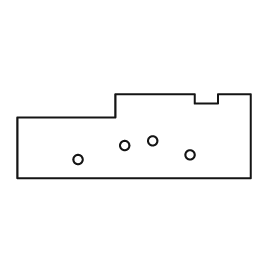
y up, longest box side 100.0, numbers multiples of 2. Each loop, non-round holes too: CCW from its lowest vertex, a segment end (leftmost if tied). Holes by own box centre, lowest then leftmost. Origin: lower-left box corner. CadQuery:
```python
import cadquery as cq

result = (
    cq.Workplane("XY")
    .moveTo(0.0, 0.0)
    .lineTo(100.0, 0.0)
    .lineTo(100.0, 36.0)
    .lineTo(86.0, 36.0)
    .lineTo(86.0, 32.0)
    .lineTo(76.0, 32.0)
    .lineTo(76.0, 36.0)
    .lineTo(42.0, 36.0)
    .lineTo(42.0, 26.0)
    .lineTo(0.0, 26.0)
    .close()
    .moveTo(26.0, 8.0)
    .circle(2.0)
    .moveTo(74.0, 10.0)
    .circle(2.0)
    .moveTo(46.0, 14.0)
    .circle(2.0)
    .moveTo(58.0, 16.0)
    .circle(2.0)
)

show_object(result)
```